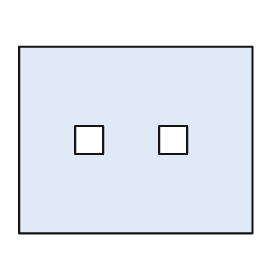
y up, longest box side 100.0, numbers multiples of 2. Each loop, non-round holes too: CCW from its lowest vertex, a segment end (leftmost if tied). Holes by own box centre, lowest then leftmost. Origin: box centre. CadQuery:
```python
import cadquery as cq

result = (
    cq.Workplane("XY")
    .moveTo(-50.0, -40.0)
    .lineTo(50.0, -40.0)
    .lineTo(50.0, 40.0)
    .lineTo(-50.0, 40.0)
    .close()
    .moveTo(-26.0, -6.0)
    .lineTo(-14.0, -6.0)
    .lineTo(-14.0, 6.0)
    .lineTo(-26.0, 6.0)
    .close()
    .moveTo(10.0, -6.0)
    .lineTo(22.0, -6.0)
    .lineTo(22.0, 6.0)
    .lineTo(10.0, 6.0)
    .close()
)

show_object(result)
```